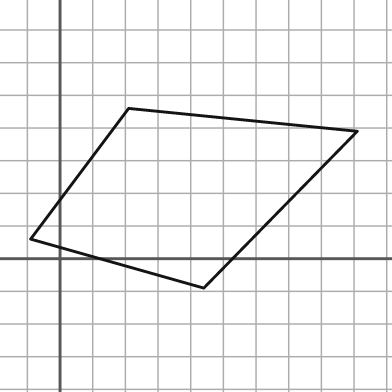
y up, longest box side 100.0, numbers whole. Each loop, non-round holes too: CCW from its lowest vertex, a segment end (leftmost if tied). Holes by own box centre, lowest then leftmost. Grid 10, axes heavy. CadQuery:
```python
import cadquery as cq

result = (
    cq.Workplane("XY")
    .moveTo(44.0, -9.0)
    .lineTo(91.0, 39.0)
    .lineTo(21.0, 46.0)
    .lineTo(-9.0, 6.0)
    .close()
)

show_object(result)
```